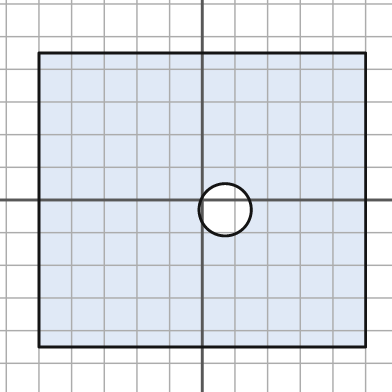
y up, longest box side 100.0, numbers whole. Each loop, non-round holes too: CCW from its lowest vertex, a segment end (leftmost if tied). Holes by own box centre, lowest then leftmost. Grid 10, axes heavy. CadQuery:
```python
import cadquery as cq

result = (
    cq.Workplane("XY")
    .moveTo(-50.0, -45.0)
    .lineTo(50.0, -45.0)
    .lineTo(50.0, 45.0)
    .lineTo(-50.0, 45.0)
    .close()
    .moveTo(7.0, -3.0)
    .circle(8.0)
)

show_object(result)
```